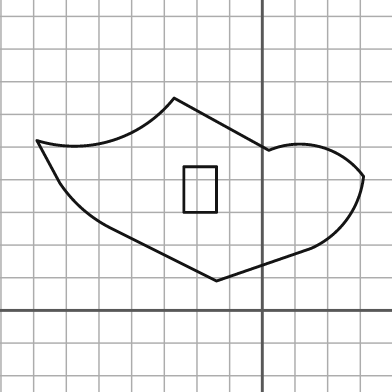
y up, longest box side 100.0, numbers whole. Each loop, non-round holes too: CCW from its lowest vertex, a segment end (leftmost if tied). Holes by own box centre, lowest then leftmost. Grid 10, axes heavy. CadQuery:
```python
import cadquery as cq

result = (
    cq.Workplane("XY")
    .moveTo(-14.0, 9.0)
    .lineTo(15.0, 19.0)
    .threePointArc((26.0, 28.0), (31.0, 41.0))
    .threePointArc((18.0, 50.0), (2.0, 49.0))
    .lineTo(-27.0, 65.0)
    .threePointArc((-46.0, 52.0), (-69.0, 52.0))
    .lineTo(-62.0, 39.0)
    .threePointArc((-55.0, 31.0), (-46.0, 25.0))
    .close()
    .moveTo(-24.0, 30.0)
    .lineTo(-14.0, 30.0)
    .lineTo(-14.0, 44.0)
    .lineTo(-24.0, 44.0)
    .close()
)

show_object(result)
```